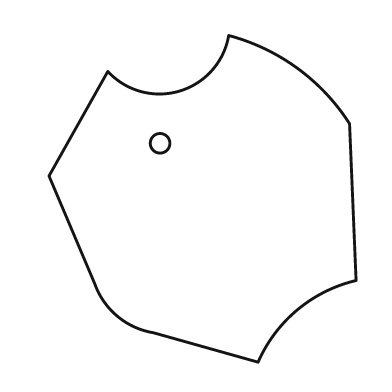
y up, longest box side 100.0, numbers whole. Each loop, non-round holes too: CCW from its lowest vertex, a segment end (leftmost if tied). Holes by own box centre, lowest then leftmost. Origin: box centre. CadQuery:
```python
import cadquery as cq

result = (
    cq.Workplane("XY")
    .moveTo(17.0, -50.0)
    .threePointArc((29.0, -34.0), (47.0, -25.0))
    .lineTo(45.0, 23.0)
    .threePointArc((29.0, 40.0), (8.0, 50.0))
    .threePointArc((-7.0, 33.0), (-29.0, 39.0))
    .lineTo(-47.0, 7.0)
    .lineTo(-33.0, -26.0)
    .threePointArc((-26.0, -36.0), (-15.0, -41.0))
    .close()
    .moveTo(-13.0, 17.0)
    .circle(3.0)
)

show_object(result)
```